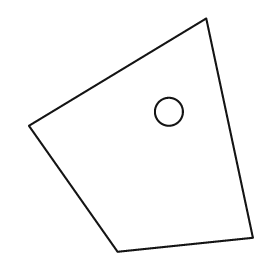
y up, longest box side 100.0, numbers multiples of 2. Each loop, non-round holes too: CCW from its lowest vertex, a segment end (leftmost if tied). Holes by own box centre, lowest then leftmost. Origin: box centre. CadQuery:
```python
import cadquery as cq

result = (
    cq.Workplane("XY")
    .moveTo(-10.0, -50.0)
    .lineTo(48.0, -44.0)
    .lineTo(28.0, 50.0)
    .lineTo(-48.0, 4.0)
    .close()
    .moveTo(12.0, 10.0)
    .circle(6.0)
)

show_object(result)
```